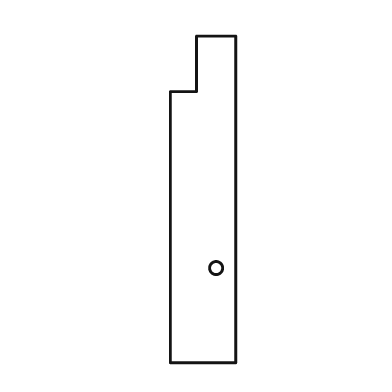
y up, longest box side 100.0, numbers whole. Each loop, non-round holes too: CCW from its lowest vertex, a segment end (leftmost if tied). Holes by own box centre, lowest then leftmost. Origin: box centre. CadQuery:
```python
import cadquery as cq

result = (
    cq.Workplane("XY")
    .moveTo(-10.0, -50.0)
    .lineTo(10.0, -50.0)
    .lineTo(10.0, 50.0)
    .lineTo(-2.0, 50.0)
    .lineTo(-2.0, 33.0)
    .lineTo(-10.0, 33.0)
    .close()
    .moveTo(4.0, -21.0)
    .circle(2.0)
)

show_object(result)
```